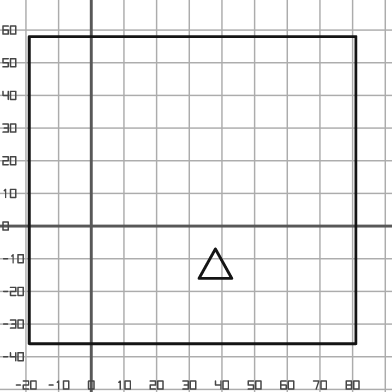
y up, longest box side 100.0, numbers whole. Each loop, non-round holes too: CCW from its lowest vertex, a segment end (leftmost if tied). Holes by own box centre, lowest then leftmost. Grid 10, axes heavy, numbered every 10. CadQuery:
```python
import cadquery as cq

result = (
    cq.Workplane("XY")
    .moveTo(-19.0, -36.0)
    .lineTo(81.0, -36.0)
    .lineTo(81.0, 58.0)
    .lineTo(-19.0, 58.0)
    .close()
    .moveTo(33.0, -16.0)
    .lineTo(43.0, -16.0)
    .lineTo(38.0, -7.0)
    .close()
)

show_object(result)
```